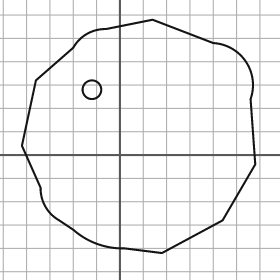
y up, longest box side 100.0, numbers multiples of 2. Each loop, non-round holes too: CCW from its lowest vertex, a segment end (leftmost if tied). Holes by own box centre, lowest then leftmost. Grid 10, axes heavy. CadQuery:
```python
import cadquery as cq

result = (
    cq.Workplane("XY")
    .moveTo(18.0, -42.0)
    .lineTo(44.0, -28.0)
    .lineTo(58.0, -4.0)
    .lineTo(56.0, 24.0)
    .threePointArc((54.0, 40.0), (40.0, 48.0))
    .lineTo(14.0, 58.0)
    .lineTo(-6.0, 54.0)
    .threePointArc((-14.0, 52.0), (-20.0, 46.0))
    .lineTo(-36.0, 32.0)
    .lineTo(-42.0, 4.0)
    .lineTo(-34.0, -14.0)
    .threePointArc((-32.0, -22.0), (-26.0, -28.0))
    .lineTo(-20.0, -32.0)
    .threePointArc((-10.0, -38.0), (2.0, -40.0))
    .close()
    .moveTo(-12.0, 28.0)
    .circle(4.0)
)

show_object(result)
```